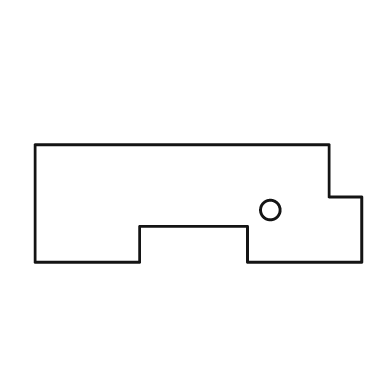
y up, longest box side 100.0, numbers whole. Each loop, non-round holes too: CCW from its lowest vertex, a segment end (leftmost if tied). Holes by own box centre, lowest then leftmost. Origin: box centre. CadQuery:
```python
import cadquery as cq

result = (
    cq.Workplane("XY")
    .moveTo(-50.0, -18.0)
    .lineTo(-18.0, -18.0)
    .lineTo(-18.0, -7.0)
    .lineTo(15.0, -7.0)
    .lineTo(15.0, -18.0)
    .lineTo(50.0, -18.0)
    .lineTo(50.0, 2.0)
    .lineTo(40.0, 2.0)
    .lineTo(40.0, 18.0)
    .lineTo(-50.0, 18.0)
    .close()
    .moveTo(22.0, -2.0)
    .circle(3.0)
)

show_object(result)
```